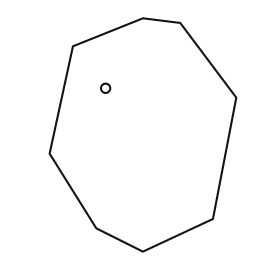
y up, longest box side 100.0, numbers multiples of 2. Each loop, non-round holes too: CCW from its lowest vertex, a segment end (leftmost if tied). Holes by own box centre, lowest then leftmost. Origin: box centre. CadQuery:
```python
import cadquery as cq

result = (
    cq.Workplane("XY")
    .moveTo(0.0, -50.0)
    .lineTo(30.0, -36.0)
    .lineTo(40.0, 16.0)
    .lineTo(16.0, 48.0)
    .lineTo(0.0, 50.0)
    .lineTo(-30.0, 38.0)
    .lineTo(-40.0, -8.0)
    .lineTo(-20.0, -40.0)
    .close()
    .moveTo(-16.0, 20.0)
    .circle(2.0)
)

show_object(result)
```